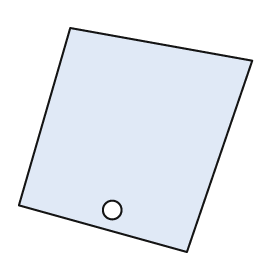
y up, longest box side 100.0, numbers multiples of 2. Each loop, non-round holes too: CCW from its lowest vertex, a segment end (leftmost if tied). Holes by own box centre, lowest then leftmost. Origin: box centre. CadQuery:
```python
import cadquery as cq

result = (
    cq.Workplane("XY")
    .moveTo(22.0, -48.0)
    .lineTo(50.0, 34.0)
    .lineTo(-28.0, 48.0)
    .lineTo(-50.0, -28.0)
    .close()
    .moveTo(-10.0, -30.0)
    .circle(4.0)
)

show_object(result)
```